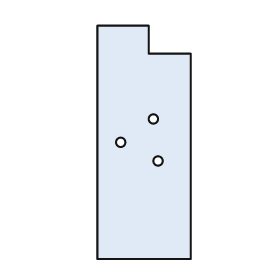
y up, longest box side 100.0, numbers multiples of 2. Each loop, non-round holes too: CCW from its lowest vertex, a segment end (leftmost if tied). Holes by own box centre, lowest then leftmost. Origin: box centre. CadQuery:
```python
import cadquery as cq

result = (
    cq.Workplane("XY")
    .moveTo(-20.0, -50.0)
    .lineTo(20.0, -50.0)
    .lineTo(20.0, 38.0)
    .lineTo(2.0, 38.0)
    .lineTo(2.0, 50.0)
    .lineTo(-20.0, 50.0)
    .close()
    .moveTo(6.0, -8.0)
    .circle(2.0)
    .moveTo(-10.0, 0.0)
    .circle(2.0)
    .moveTo(4.0, 10.0)
    .circle(2.0)
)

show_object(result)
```